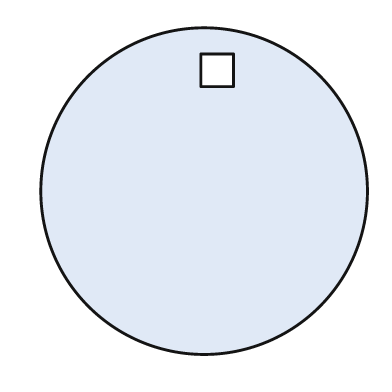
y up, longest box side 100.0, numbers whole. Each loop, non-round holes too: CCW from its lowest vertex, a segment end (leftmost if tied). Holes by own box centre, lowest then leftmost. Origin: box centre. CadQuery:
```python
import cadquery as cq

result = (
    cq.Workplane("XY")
    .moveTo(0.0, 0.0)
    .circle(50.0)
    .moveTo(-1.0, 32.0)
    .lineTo(9.0, 32.0)
    .lineTo(9.0, 42.0)
    .lineTo(-1.0, 42.0)
    .close()
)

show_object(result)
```